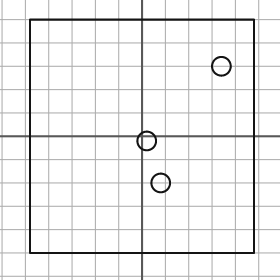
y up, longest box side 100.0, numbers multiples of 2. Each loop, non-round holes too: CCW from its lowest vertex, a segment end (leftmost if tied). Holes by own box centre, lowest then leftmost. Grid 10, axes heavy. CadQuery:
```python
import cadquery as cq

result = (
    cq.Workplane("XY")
    .moveTo(-48.0, -50.0)
    .lineTo(48.0, -50.0)
    .lineTo(48.0, 50.0)
    .lineTo(-48.0, 50.0)
    .close()
    .moveTo(8.0, -20.0)
    .circle(4.0)
    .moveTo(2.0, -2.0)
    .circle(4.0)
    .moveTo(34.0, 30.0)
    .circle(4.0)
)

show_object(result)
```